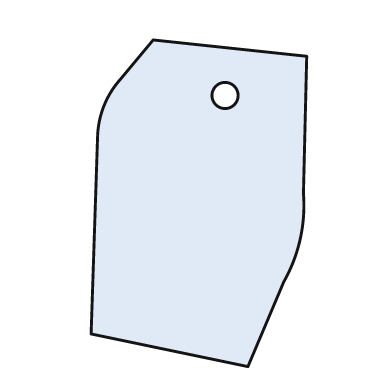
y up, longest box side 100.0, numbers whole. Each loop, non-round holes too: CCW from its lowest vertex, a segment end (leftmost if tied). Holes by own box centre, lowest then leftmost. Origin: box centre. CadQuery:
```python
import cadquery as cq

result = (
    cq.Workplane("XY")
    .moveTo(15.0, -50.0)
    .lineTo(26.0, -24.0)
    .threePointArc((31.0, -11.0), (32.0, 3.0))
    .lineTo(33.0, 45.0)
    .lineTo(-14.0, 50.0)
    .lineTo(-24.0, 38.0)
    .threePointArc((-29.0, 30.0), (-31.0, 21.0))
    .lineTo(-33.0, -40.0)
    .close()
    .moveTo(8.0, 33.0)
    .circle(4.0)
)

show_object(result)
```